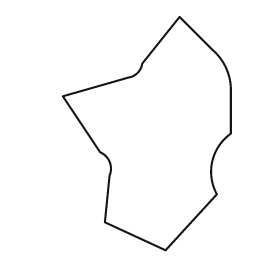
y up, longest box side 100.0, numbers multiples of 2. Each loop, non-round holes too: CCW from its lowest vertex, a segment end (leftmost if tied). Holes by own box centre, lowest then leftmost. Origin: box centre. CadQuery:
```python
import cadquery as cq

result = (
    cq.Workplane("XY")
    .moveTo(8.0, -50.0)
    .lineTo(30.0, -26.0)
    .threePointArc((28.0, -12.0), (36.0, 0.0))
    .lineTo(36.0, 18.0)
    .threePointArc((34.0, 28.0), (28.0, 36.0))
    .lineTo(14.0, 50.0)
    .lineTo(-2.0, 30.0)
    .threePointArc((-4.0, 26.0), (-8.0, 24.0))
    .lineTo(-36.0, 16.0)
    .lineTo(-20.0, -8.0)
    .threePointArc((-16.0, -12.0), (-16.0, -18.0))
    .lineTo(-18.0, -38.0)
    .close()
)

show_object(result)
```